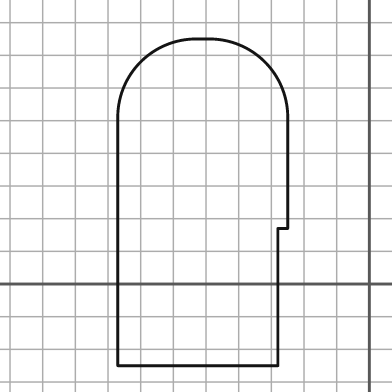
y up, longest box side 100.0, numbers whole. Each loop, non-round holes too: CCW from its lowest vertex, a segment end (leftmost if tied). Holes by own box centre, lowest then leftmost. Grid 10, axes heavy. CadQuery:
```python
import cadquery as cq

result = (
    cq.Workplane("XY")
    .moveTo(-77.0, -25.0)
    .lineTo(-28.0, -25.0)
    .lineTo(-28.0, 17.0)
    .lineTo(-25.0, 17.0)
    .lineTo(-25.0, 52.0)
    .threePointArc((-32.0, 68.0), (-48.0, 75.0))
    .lineTo(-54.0, 75.0)
    .threePointArc((-70.0, 68.0), (-77.0, 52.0))
    .close()
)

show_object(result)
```